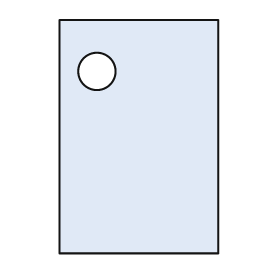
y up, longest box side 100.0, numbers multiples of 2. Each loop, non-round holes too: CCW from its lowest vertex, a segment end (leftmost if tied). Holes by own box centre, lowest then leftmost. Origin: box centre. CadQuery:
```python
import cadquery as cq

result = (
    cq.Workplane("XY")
    .moveTo(-34.0, -50.0)
    .lineTo(34.0, -50.0)
    .lineTo(34.0, 50.0)
    .lineTo(-34.0, 50.0)
    .close()
    .moveTo(-18.0, 28.0)
    .circle(8.0)
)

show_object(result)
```